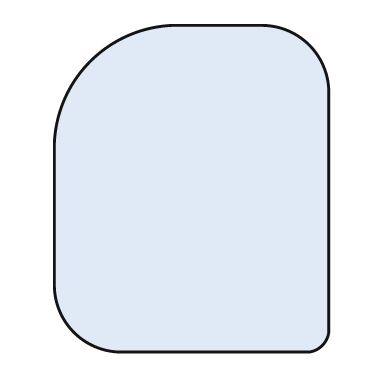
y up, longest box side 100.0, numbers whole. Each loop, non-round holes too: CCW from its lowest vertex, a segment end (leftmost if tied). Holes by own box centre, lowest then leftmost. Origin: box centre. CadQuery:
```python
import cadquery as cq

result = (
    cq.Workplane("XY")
    .moveTo(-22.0, -50.0)
    .lineTo(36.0, -50.0)
    .threePointArc((40.0, -48.0), (42.0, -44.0))
    .lineTo(42.0, 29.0)
    .threePointArc((36.0, 44.0), (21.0, 50.0))
    .lineTo(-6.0, 50.0)
    .threePointArc((-31.0, 39.0), (-42.0, 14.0))
    .lineTo(-42.0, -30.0)
    .threePointArc((-36.0, -44.0), (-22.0, -50.0))
    .close()
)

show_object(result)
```